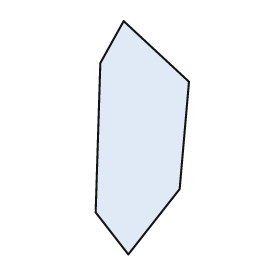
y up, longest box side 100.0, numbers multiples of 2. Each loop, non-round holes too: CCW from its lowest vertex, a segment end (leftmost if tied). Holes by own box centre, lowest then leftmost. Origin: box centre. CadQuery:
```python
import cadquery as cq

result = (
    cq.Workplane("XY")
    .moveTo(-6.0, -50.0)
    .lineTo(16.0, -22.0)
    .lineTo(20.0, 24.0)
    .lineTo(-8.0, 50.0)
    .lineTo(-18.0, 32.0)
    .lineTo(-20.0, -32.0)
    .close()
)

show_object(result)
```